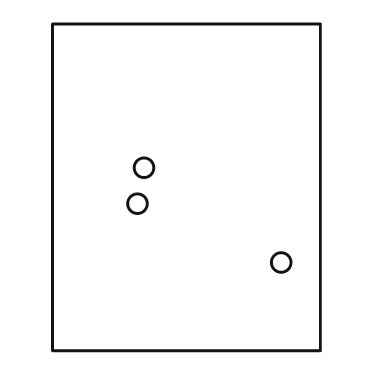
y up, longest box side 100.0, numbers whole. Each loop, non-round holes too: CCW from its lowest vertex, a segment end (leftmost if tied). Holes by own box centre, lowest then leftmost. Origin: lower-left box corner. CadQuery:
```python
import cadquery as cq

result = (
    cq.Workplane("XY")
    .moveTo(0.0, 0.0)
    .lineTo(82.0, 0.0)
    .lineTo(82.0, 100.0)
    .lineTo(0.0, 100.0)
    .close()
    .moveTo(70.0, 27.0)
    .circle(3.0)
    .moveTo(26.0, 45.0)
    .circle(3.0)
    .moveTo(28.0, 56.0)
    .circle(3.0)
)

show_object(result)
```